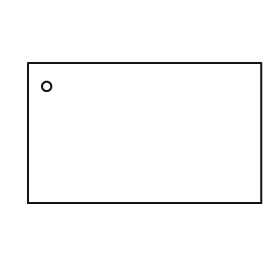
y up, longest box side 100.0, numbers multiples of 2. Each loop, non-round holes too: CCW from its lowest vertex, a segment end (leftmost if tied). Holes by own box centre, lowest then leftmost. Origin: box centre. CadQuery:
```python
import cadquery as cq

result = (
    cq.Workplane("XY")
    .moveTo(-50.0, -30.0)
    .lineTo(50.0, -30.0)
    .lineTo(50.0, 30.0)
    .lineTo(-50.0, 30.0)
    .close()
    .moveTo(-42.0, 20.0)
    .circle(2.0)
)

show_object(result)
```